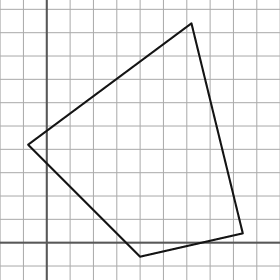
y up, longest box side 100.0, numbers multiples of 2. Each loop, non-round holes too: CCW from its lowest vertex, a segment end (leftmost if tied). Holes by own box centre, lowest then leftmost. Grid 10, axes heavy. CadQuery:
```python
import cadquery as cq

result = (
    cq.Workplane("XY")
    .moveTo(40.0, -6.0)
    .lineTo(84.0, 4.0)
    .lineTo(62.0, 94.0)
    .lineTo(-8.0, 42.0)
    .close()
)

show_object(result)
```